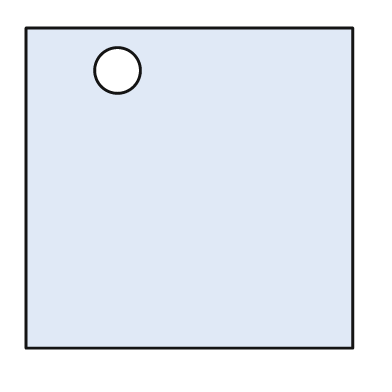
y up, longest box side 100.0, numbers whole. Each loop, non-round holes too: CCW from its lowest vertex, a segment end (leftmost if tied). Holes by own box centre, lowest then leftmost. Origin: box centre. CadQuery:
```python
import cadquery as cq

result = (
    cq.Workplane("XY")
    .moveTo(-50.0, -49.0)
    .lineTo(50.0, -49.0)
    .lineTo(50.0, 49.0)
    .lineTo(-50.0, 49.0)
    .close()
    .moveTo(-22.0, 36.0)
    .circle(7.0)
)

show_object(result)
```